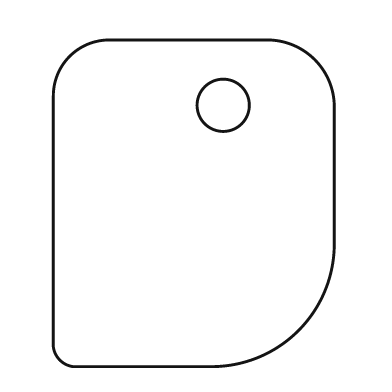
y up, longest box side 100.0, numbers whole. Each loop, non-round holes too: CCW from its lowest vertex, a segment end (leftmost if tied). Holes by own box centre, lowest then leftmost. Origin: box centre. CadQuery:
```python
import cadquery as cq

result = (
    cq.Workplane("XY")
    .moveTo(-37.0, -50.0)
    .lineTo(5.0, -50.0)
    .threePointArc((32.0, -39.0), (43.0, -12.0))
    .lineTo(43.0, 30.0)
    .threePointArc((37.0, 44.0), (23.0, 50.0))
    .lineTo(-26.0, 50.0)
    .threePointArc((-38.0, 45.0), (-43.0, 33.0))
    .lineTo(-43.0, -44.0)
    .threePointArc((-41.0, -48.0), (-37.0, -50.0))
    .close()
    .moveTo(9.0, 30.0)
    .circle(8.0)
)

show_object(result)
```